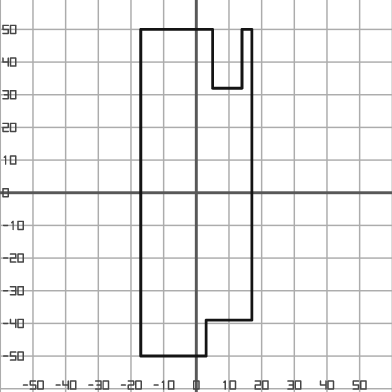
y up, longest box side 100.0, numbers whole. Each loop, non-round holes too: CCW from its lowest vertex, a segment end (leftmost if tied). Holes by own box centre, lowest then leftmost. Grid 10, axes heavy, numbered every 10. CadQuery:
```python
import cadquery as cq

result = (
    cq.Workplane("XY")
    .moveTo(-17.0, -50.0)
    .lineTo(3.0, -50.0)
    .lineTo(3.0, -39.0)
    .lineTo(17.0, -39.0)
    .lineTo(17.0, 50.0)
    .lineTo(14.0, 50.0)
    .lineTo(14.0, 32.0)
    .lineTo(5.0, 32.0)
    .lineTo(5.0, 50.0)
    .lineTo(-17.0, 50.0)
    .close()
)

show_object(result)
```